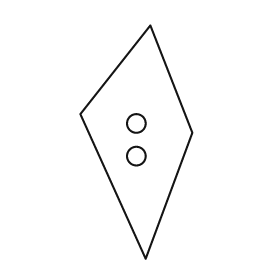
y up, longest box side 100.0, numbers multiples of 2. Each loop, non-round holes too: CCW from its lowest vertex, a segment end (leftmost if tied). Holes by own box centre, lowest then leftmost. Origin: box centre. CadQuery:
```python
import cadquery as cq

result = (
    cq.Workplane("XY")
    .moveTo(4.0, -50.0)
    .lineTo(24.0, 4.0)
    .lineTo(6.0, 50.0)
    .lineTo(-24.0, 12.0)
    .close()
    .moveTo(0.0, -6.0)
    .circle(4.0)
    .moveTo(0.0, 8.0)
    .circle(4.0)
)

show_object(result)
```